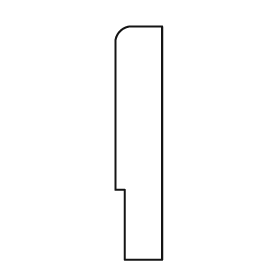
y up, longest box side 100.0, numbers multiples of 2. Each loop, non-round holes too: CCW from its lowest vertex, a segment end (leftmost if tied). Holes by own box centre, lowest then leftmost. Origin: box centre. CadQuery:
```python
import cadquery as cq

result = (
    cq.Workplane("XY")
    .moveTo(-6.0, -50.0)
    .lineTo(10.0, -50.0)
    .lineTo(10.0, 50.0)
    .lineTo(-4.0, 50.0)
    .threePointArc((-8.0, 48.0), (-10.0, 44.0))
    .lineTo(-10.0, -20.0)
    .lineTo(-6.0, -20.0)
    .close()
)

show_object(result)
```